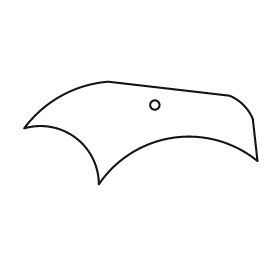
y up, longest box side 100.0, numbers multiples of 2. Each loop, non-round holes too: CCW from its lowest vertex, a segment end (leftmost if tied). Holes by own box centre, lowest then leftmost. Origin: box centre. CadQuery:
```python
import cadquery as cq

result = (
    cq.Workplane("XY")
    .moveTo(-18.0, -22.0)
    .threePointArc((14.0, -2.0), (50.0, -12.0))
    .lineTo(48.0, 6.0)
    .threePointArc((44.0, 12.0), (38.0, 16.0))
    .lineTo(-14.0, 22.0)
    .threePointArc((-34.0, 16.0), (-50.0, 2.0))
    .threePointArc((-28.0, -2.0), (-18.0, -22.0))
    .close()
    .moveTo(6.0, 12.0)
    .circle(2.0)
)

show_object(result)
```